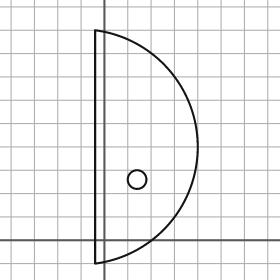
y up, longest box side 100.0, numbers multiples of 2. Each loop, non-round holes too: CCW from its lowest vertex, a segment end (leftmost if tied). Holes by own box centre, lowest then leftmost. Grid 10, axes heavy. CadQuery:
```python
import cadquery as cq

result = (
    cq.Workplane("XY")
    .moveTo(-4.0, -10.0)
    .threePointArc((40.0, 40.0), (-4.0, 90.0))
    .close()
    .moveTo(14.0, 26.0)
    .circle(4.0)
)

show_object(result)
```